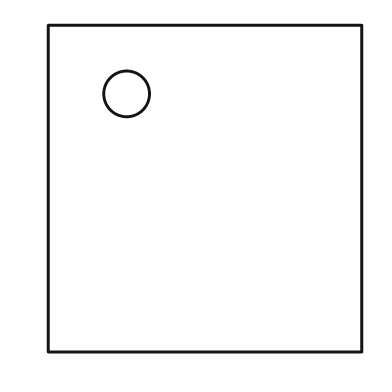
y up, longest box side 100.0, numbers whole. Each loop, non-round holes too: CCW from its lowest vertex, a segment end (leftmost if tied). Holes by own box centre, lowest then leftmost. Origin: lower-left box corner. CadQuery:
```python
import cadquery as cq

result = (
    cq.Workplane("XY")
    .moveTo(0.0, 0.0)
    .lineTo(96.0, 0.0)
    .lineTo(96.0, 100.0)
    .lineTo(0.0, 100.0)
    .close()
    .moveTo(24.0, 79.0)
    .circle(7.0)
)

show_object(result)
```